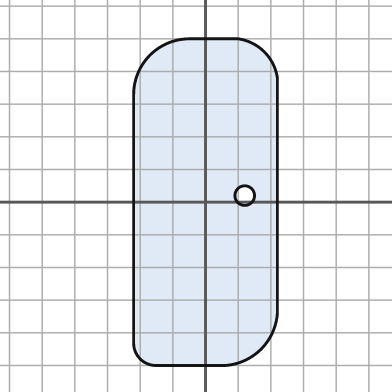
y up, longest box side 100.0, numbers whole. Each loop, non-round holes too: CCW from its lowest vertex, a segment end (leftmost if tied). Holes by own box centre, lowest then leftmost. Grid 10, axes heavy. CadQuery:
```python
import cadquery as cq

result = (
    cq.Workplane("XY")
    .moveTo(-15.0, -50.0)
    .lineTo(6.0, -50.0)
    .threePointArc((17.0, -45.0), (22.0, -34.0))
    .lineTo(22.0, 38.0)
    .threePointArc((18.0, 46.0), (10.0, 50.0))
    .lineTo(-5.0, 50.0)
    .threePointArc((-17.0, 45.0), (-22.0, 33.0))
    .lineTo(-22.0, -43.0)
    .threePointArc((-20.0, -48.0), (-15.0, -50.0))
    .close()
    .moveTo(12.0, 2.0)
    .circle(3.0)
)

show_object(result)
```